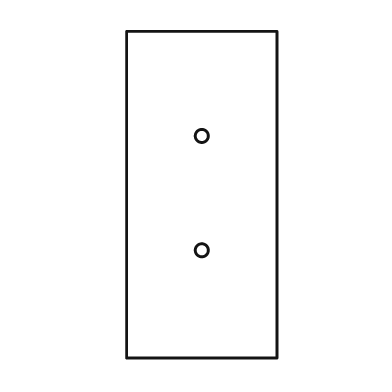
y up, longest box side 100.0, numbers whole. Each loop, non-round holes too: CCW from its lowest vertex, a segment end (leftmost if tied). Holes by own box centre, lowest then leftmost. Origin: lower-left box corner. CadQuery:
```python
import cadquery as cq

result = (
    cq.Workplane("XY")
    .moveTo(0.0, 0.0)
    .lineTo(46.0, 0.0)
    .lineTo(46.0, 100.0)
    .lineTo(0.0, 100.0)
    .close()
    .moveTo(23.0, 33.0)
    .circle(2.0)
    .moveTo(23.0, 68.0)
    .circle(2.0)
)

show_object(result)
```